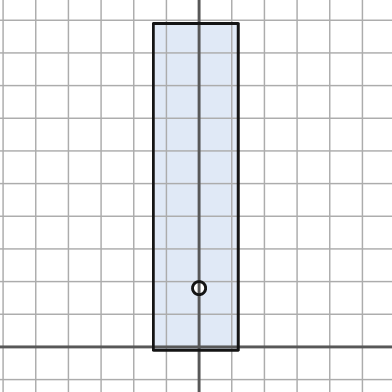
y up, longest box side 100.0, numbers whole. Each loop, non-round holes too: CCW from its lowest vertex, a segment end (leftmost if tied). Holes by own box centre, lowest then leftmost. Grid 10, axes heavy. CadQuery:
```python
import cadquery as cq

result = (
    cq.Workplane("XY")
    .moveTo(-14.0, -1.0)
    .lineTo(12.0, -1.0)
    .lineTo(12.0, 99.0)
    .lineTo(-14.0, 99.0)
    .close()
    .moveTo(0.0, 18.0)
    .circle(2.0)
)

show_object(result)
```